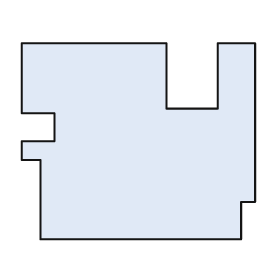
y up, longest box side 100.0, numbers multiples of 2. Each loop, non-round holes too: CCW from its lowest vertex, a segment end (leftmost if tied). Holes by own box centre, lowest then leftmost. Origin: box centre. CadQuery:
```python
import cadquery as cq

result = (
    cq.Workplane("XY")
    .moveTo(-42.0, -42.0)
    .lineTo(44.0, -42.0)
    .lineTo(44.0, -26.0)
    .lineTo(50.0, -26.0)
    .lineTo(50.0, 42.0)
    .lineTo(34.0, 42.0)
    .lineTo(34.0, 14.0)
    .lineTo(12.0, 14.0)
    .lineTo(12.0, 42.0)
    .lineTo(-50.0, 42.0)
    .lineTo(-50.0, 12.0)
    .lineTo(-36.0, 12.0)
    .lineTo(-36.0, 0.0)
    .lineTo(-50.0, 0.0)
    .lineTo(-50.0, -8.0)
    .lineTo(-42.0, -8.0)
    .close()
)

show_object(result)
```